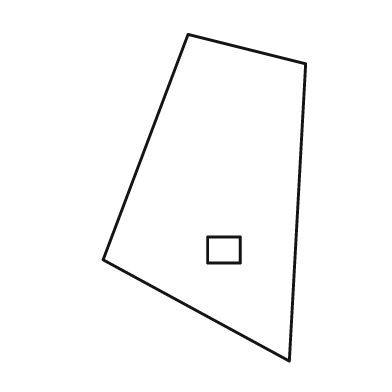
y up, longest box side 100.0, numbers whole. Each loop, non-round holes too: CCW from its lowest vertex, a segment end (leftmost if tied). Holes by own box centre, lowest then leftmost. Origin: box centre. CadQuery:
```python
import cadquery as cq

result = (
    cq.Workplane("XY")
    .moveTo(26.0, -50.0)
    .lineTo(31.0, 41.0)
    .lineTo(-5.0, 50.0)
    .lineTo(-31.0, -19.0)
    .close()
    .moveTo(1.0, -20.0)
    .lineTo(11.0, -20.0)
    .lineTo(11.0, -12.0)
    .lineTo(1.0, -12.0)
    .close()
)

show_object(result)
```